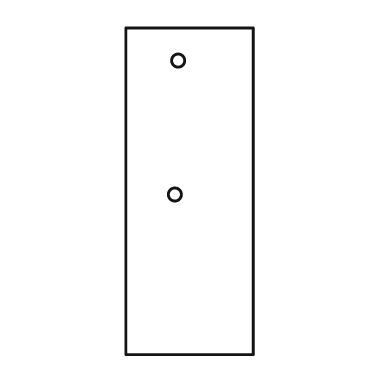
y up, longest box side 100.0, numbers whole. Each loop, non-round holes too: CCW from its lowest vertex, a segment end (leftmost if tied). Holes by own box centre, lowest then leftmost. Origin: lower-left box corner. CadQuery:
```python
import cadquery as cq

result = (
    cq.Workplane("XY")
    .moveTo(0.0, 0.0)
    .lineTo(39.0, 0.0)
    .lineTo(39.0, 100.0)
    .lineTo(0.0, 100.0)
    .close()
    .moveTo(15.0, 49.0)
    .circle(2.0)
    .moveTo(16.0, 90.0)
    .circle(2.0)
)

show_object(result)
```